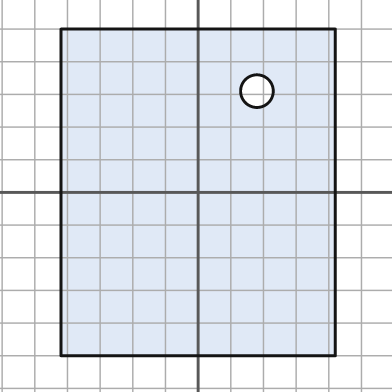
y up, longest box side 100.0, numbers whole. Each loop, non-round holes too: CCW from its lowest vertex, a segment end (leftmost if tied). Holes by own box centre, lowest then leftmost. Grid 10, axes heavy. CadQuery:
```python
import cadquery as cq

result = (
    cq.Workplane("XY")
    .moveTo(-42.0, -50.0)
    .lineTo(42.0, -50.0)
    .lineTo(42.0, 50.0)
    .lineTo(-42.0, 50.0)
    .close()
    .moveTo(18.0, 31.0)
    .circle(5.0)
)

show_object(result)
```